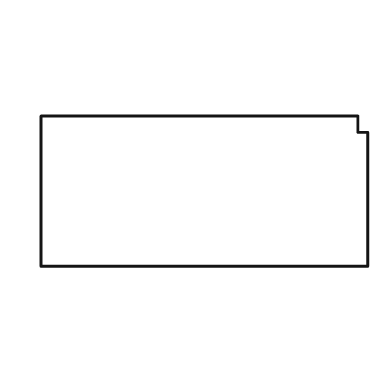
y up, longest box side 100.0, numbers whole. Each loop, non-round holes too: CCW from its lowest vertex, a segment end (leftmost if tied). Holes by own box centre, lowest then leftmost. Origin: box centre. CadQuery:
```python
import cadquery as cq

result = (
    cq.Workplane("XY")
    .moveTo(-50.0, -23.0)
    .lineTo(50.0, -23.0)
    .lineTo(50.0, 18.0)
    .lineTo(47.0, 18.0)
    .lineTo(47.0, 23.0)
    .lineTo(-50.0, 23.0)
    .close()
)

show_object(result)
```